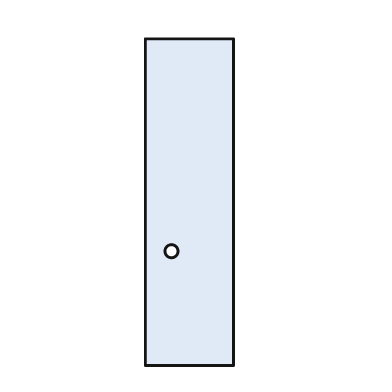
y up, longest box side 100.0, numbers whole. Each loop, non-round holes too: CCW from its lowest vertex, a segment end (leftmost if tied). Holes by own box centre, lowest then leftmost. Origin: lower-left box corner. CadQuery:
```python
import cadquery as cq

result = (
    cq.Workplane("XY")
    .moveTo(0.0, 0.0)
    .lineTo(27.0, 0.0)
    .lineTo(27.0, 100.0)
    .lineTo(0.0, 100.0)
    .close()
    .moveTo(8.0, 35.0)
    .circle(2.0)
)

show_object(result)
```